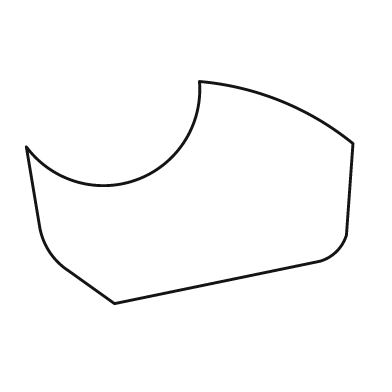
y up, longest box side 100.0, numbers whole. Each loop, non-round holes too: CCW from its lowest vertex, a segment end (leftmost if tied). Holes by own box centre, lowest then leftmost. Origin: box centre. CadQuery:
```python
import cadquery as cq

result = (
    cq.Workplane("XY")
    .moveTo(-23.0, -34.0)
    .lineTo(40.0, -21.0)
    .threePointArc((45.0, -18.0), (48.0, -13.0))
    .lineTo(50.0, 15.0)
    .threePointArc((28.0, 28.0), (3.0, 34.0))
    .threePointArc((-16.0, 4.0), (-50.0, 14.0))
    .lineTo(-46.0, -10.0)
    .threePointArc((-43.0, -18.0), (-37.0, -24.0))
    .close()
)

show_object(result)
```